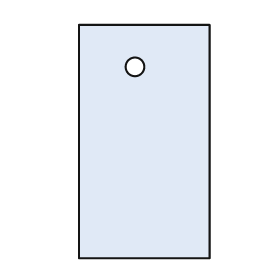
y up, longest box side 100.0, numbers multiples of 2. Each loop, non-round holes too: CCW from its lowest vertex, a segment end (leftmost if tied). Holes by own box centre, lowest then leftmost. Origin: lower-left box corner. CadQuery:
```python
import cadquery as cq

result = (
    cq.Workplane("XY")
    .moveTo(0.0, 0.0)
    .lineTo(56.0, 0.0)
    .lineTo(56.0, 100.0)
    .lineTo(0.0, 100.0)
    .close()
    .moveTo(24.0, 82.0)
    .circle(4.0)
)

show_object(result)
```